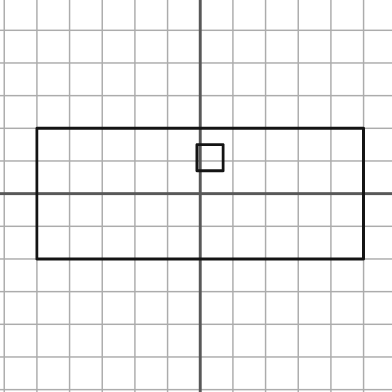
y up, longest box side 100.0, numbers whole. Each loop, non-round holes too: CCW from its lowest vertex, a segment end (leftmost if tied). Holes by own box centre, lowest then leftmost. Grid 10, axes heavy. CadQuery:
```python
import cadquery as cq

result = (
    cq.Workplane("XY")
    .moveTo(-50.0, -20.0)
    .lineTo(50.0, -20.0)
    .lineTo(50.0, 20.0)
    .lineTo(-50.0, 20.0)
    .close()
    .moveTo(-1.0, 7.0)
    .lineTo(7.0, 7.0)
    .lineTo(7.0, 15.0)
    .lineTo(-1.0, 15.0)
    .close()
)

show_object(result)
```